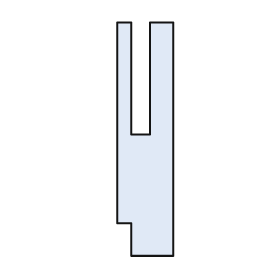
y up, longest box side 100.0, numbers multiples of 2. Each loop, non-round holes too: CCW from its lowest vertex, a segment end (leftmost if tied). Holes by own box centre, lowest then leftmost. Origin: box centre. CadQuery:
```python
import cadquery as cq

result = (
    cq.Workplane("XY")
    .moveTo(-6.0, -50.0)
    .lineTo(12.0, -50.0)
    .lineTo(12.0, 50.0)
    .lineTo(2.0, 50.0)
    .lineTo(2.0, 2.0)
    .lineTo(-6.0, 2.0)
    .lineTo(-6.0, 50.0)
    .lineTo(-12.0, 50.0)
    .lineTo(-12.0, -36.0)
    .lineTo(-6.0, -36.0)
    .close()
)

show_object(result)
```